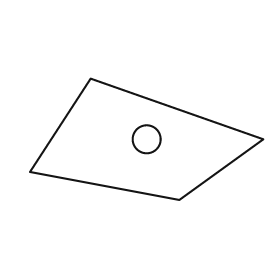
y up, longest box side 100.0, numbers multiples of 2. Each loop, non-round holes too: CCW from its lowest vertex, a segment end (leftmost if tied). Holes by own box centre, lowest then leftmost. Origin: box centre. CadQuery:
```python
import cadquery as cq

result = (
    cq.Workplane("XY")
    .moveTo(14.0, -26.0)
    .lineTo(50.0, 0.0)
    .lineTo(-24.0, 26.0)
    .lineTo(-50.0, -14.0)
    .close()
    .moveTo(0.0, 0.0)
    .circle(6.0)
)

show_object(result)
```